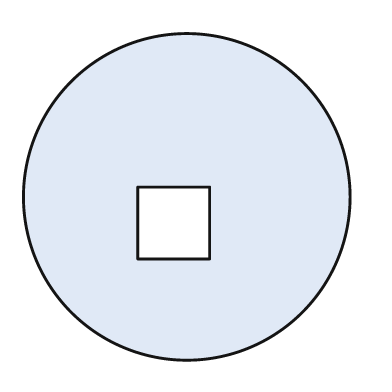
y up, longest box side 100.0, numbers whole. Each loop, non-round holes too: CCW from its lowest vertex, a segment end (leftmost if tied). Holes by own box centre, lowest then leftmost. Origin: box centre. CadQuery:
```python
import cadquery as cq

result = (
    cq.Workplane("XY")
    .moveTo(0.0, 0.0)
    .circle(50.0)
    .moveTo(-15.0, -19.0)
    .lineTo(7.0, -19.0)
    .lineTo(7.0, 3.0)
    .lineTo(-15.0, 3.0)
    .close()
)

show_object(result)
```